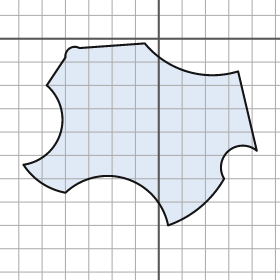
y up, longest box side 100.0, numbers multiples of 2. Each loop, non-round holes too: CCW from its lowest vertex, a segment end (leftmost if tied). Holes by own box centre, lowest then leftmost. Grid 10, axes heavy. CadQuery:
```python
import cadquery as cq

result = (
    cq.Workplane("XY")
    .moveTo(4.0, -80.0)
    .threePointArc((18.0, -72.0), (28.0, -60.0))
    .threePointArc((30.0, -48.0), (42.0, -48.0))
    .lineTo(34.0, -14.0)
    .threePointArc((12.0, -14.0), (-6.0, -2.0))
    .lineTo(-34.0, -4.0)
    .threePointArc((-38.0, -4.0), (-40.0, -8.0))
    .lineTo(-48.0, -20.0)
    .threePointArc((-42.0, -40.0), (-58.0, -54.0))
    .threePointArc((-50.0, -62.0), (-40.0, -66.0))
    .threePointArc((-14.0, -60.0), (4.0, -80.0))
    .close()
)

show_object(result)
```